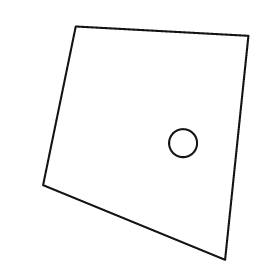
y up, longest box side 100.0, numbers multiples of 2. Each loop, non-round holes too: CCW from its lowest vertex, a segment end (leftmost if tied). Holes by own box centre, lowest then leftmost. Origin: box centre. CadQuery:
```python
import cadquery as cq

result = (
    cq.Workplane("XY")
    .moveTo(34.0, -50.0)
    .lineTo(44.0, 46.0)
    .lineTo(-30.0, 50.0)
    .lineTo(-44.0, -18.0)
    .close()
    .moveTo(16.0, 0.0)
    .circle(6.0)
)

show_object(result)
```